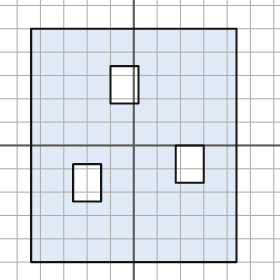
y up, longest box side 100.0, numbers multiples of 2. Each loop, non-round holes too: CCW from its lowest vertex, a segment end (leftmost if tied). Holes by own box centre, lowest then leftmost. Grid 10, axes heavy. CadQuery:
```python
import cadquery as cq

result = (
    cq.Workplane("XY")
    .moveTo(-44.0, -50.0)
    .lineTo(44.0, -50.0)
    .lineTo(44.0, 50.0)
    .lineTo(-44.0, 50.0)
    .close()
    .moveTo(-26.0, -24.0)
    .lineTo(-14.0, -24.0)
    .lineTo(-14.0, -8.0)
    .lineTo(-26.0, -8.0)
    .close()
    .moveTo(18.0, -16.0)
    .lineTo(30.0, -16.0)
    .lineTo(30.0, 0.0)
    .lineTo(18.0, 0.0)
    .close()
    .moveTo(-10.0, 18.0)
    .lineTo(2.0, 18.0)
    .lineTo(2.0, 34.0)
    .lineTo(-10.0, 34.0)
    .close()
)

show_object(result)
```